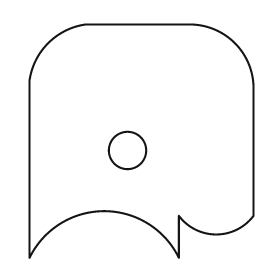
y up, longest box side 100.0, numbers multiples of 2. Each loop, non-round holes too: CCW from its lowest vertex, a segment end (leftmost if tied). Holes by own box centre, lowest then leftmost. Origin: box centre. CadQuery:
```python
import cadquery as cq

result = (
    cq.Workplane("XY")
    .moveTo(-48.0, -50.0)
    .threePointArc((-16.0, -30.0), (16.0, -50.0))
    .lineTo(16.0, -32.0)
    .threePointArc((32.0, -40.0), (48.0, -32.0))
    .lineTo(48.0, 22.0)
    .threePointArc((40.0, 42.0), (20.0, 50.0))
    .lineTo(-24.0, 50.0)
    .threePointArc((-40.0, 42.0), (-48.0, 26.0))
    .close()
    .moveTo(-6.0, -4.0)
    .circle(8.0)
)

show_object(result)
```